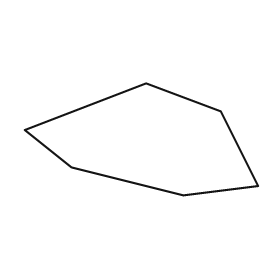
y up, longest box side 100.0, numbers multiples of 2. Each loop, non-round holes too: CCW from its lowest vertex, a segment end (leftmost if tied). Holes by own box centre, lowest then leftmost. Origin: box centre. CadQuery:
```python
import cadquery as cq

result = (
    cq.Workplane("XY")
    .moveTo(18.0, -24.0)
    .lineTo(50.0, -20.0)
    .lineTo(34.0, 12.0)
    .lineTo(2.0, 24.0)
    .lineTo(-50.0, 4.0)
    .lineTo(-30.0, -12.0)
    .close()
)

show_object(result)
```